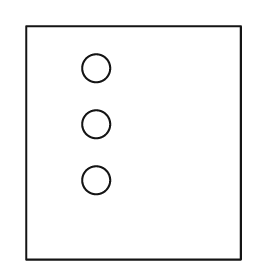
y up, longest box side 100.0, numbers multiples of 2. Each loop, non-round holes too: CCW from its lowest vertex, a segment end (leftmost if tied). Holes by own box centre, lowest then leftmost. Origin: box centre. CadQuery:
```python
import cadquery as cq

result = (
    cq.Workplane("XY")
    .moveTo(-46.0, -50.0)
    .lineTo(46.0, -50.0)
    .lineTo(46.0, 50.0)
    .lineTo(-46.0, 50.0)
    .close()
    .moveTo(-16.0, -16.0)
    .circle(6.0)
    .moveTo(-16.0, 8.0)
    .circle(6.0)
    .moveTo(-16.0, 32.0)
    .circle(6.0)
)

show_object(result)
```